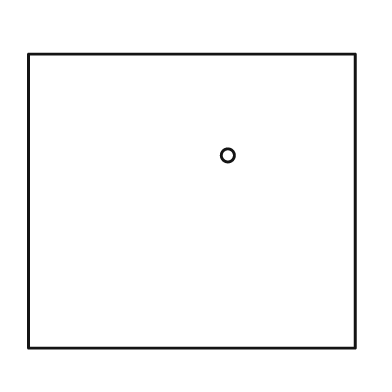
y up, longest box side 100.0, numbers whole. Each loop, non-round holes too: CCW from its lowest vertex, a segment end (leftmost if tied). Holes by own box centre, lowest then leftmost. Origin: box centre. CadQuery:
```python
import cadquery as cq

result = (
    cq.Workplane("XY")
    .moveTo(-50.0, -45.0)
    .lineTo(50.0, -45.0)
    .lineTo(50.0, 45.0)
    .lineTo(-50.0, 45.0)
    .close()
    .moveTo(11.0, 14.0)
    .circle(2.0)
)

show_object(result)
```